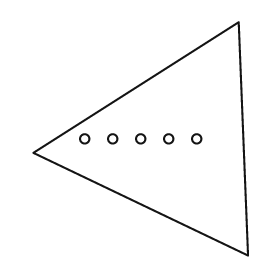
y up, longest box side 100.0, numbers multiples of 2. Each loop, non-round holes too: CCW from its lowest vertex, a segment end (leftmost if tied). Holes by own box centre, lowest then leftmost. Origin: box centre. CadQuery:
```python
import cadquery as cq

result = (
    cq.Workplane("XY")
    .moveTo(46.0, -50.0)
    .lineTo(42.0, 50.0)
    .lineTo(-46.0, -6.0)
    .close()
    .moveTo(-24.0, 0.0)
    .circle(2.0)
    .moveTo(-12.0, 0.0)
    .circle(2.0)
    .moveTo(0.0, 0.0)
    .circle(2.0)
    .moveTo(12.0, 0.0)
    .circle(2.0)
    .moveTo(24.0, 0.0)
    .circle(2.0)
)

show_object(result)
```